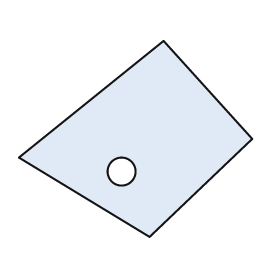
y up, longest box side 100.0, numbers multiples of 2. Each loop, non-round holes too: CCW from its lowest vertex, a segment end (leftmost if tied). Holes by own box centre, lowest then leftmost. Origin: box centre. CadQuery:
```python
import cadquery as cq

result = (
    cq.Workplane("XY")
    .moveTo(6.0, -42.0)
    .lineTo(50.0, 0.0)
    .lineTo(12.0, 42.0)
    .lineTo(-50.0, -8.0)
    .close()
    .moveTo(-6.0, -14.0)
    .circle(6.0)
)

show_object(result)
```